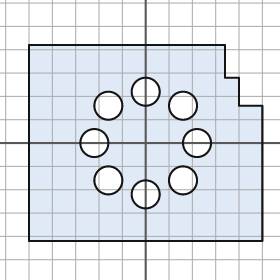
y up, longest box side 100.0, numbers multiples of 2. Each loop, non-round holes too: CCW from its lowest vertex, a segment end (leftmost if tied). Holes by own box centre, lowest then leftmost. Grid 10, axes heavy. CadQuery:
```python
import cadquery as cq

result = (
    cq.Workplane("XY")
    .moveTo(-50.0, -42.0)
    .lineTo(50.0, -42.0)
    .lineTo(50.0, 16.0)
    .lineTo(40.0, 16.0)
    .lineTo(40.0, 28.0)
    .lineTo(34.0, 28.0)
    .lineTo(34.0, 42.0)
    .lineTo(-50.0, 42.0)
    .close()
    .moveTo(0.0, -22.0)
    .circle(6.0)
    .moveTo(-16.0, -16.0)
    .circle(6.0)
    .moveTo(16.0, -16.0)
    .circle(6.0)
    .moveTo(-22.0, 0.0)
    .circle(6.0)
    .moveTo(22.0, 0.0)
    .circle(6.0)
    .moveTo(-16.0, 16.0)
    .circle(6.0)
    .moveTo(16.0, 16.0)
    .circle(6.0)
    .moveTo(0.0, 22.0)
    .circle(6.0)
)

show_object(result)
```